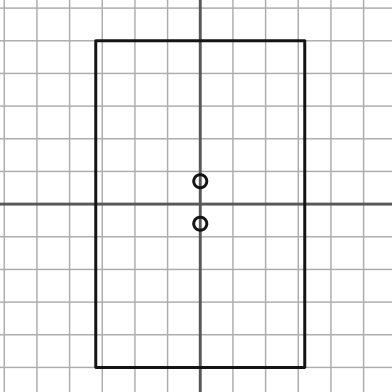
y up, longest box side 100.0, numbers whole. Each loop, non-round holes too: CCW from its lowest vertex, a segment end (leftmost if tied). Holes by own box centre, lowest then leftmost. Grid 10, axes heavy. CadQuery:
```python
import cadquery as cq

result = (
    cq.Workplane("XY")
    .moveTo(-32.0, -50.0)
    .lineTo(32.0, -50.0)
    .lineTo(32.0, 50.0)
    .lineTo(-32.0, 50.0)
    .close()
    .moveTo(0.0, -6.0)
    .circle(2.0)
    .moveTo(0.0, 7.0)
    .circle(2.0)
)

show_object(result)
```